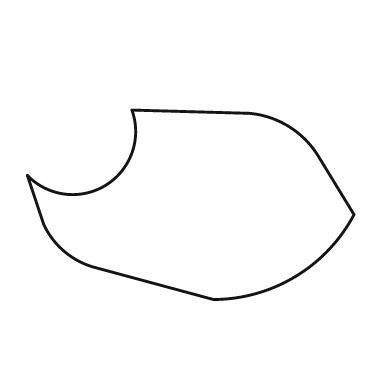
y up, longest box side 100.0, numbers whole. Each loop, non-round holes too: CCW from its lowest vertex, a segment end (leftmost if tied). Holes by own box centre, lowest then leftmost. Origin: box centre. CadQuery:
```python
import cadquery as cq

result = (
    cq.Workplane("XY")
    .moveTo(7.0, -29.0)
    .threePointArc((32.0, -22.0), (50.0, -3.0))
    .lineTo(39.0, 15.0)
    .threePointArc((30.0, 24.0), (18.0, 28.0))
    .lineTo(-18.0, 29.0)
    .threePointArc((-26.0, 6.0), (-50.0, 9.0))
    .lineTo(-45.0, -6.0)
    .threePointArc((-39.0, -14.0), (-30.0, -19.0))
    .close()
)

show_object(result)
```